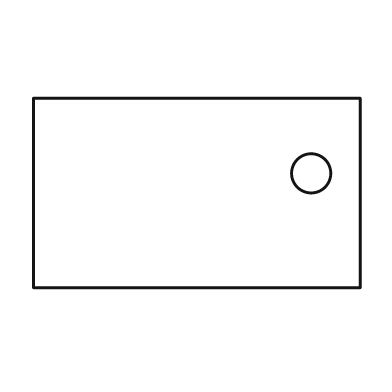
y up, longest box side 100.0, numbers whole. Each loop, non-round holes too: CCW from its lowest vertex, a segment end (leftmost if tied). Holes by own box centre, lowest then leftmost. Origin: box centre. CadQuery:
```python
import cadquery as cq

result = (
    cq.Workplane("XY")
    .moveTo(-50.0, -29.0)
    .lineTo(50.0, -29.0)
    .lineTo(50.0, 29.0)
    .lineTo(-50.0, 29.0)
    .close()
    .moveTo(35.0, 6.0)
    .circle(6.0)
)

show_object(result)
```